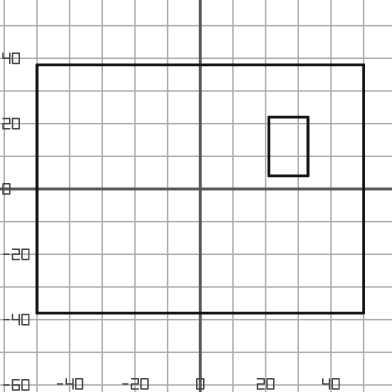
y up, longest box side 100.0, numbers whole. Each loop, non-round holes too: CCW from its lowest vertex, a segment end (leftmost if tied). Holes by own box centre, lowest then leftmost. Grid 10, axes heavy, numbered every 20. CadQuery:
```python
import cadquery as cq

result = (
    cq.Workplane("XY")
    .moveTo(-50.0, -38.0)
    .lineTo(50.0, -38.0)
    .lineTo(50.0, 38.0)
    .lineTo(-50.0, 38.0)
    .close()
    .moveTo(21.0, 4.0)
    .lineTo(33.0, 4.0)
    .lineTo(33.0, 22.0)
    .lineTo(21.0, 22.0)
    .close()
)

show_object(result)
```